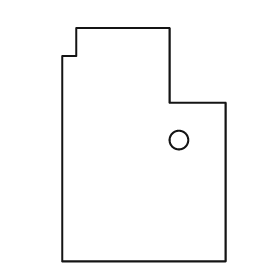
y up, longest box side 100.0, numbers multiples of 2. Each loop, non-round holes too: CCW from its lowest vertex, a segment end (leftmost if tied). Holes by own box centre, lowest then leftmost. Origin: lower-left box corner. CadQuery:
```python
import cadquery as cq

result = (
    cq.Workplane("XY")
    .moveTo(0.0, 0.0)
    .lineTo(70.0, 0.0)
    .lineTo(70.0, 68.0)
    .lineTo(46.0, 68.0)
    .lineTo(46.0, 100.0)
    .lineTo(6.0, 100.0)
    .lineTo(6.0, 88.0)
    .lineTo(0.0, 88.0)
    .close()
    .moveTo(50.0, 52.0)
    .circle(4.0)
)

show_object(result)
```